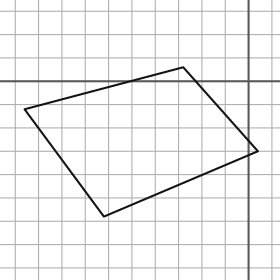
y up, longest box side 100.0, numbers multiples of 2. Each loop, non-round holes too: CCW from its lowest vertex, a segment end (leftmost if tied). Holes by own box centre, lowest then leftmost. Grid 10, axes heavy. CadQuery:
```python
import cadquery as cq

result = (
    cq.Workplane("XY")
    .moveTo(-62.0, -58.0)
    .lineTo(4.0, -30.0)
    .lineTo(-28.0, 6.0)
    .lineTo(-96.0, -12.0)
    .close()
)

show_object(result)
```